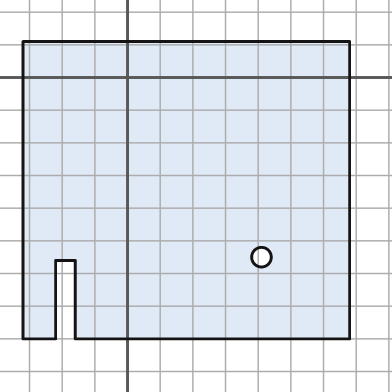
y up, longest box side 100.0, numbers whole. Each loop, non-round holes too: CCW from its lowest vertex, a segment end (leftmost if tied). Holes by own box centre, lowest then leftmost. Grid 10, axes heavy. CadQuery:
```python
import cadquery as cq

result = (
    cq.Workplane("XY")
    .moveTo(-32.0, -80.0)
    .lineTo(-22.0, -80.0)
    .lineTo(-22.0, -56.0)
    .lineTo(-16.0, -56.0)
    .lineTo(-16.0, -80.0)
    .lineTo(68.0, -80.0)
    .lineTo(68.0, 11.0)
    .lineTo(-32.0, 11.0)
    .close()
    .moveTo(41.0, -55.0)
    .circle(3.0)
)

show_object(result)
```